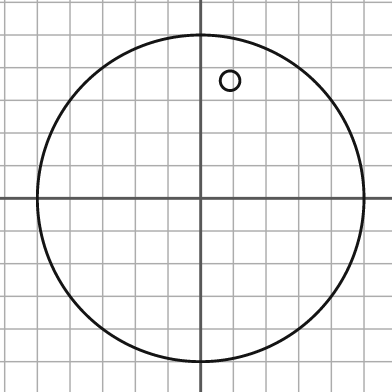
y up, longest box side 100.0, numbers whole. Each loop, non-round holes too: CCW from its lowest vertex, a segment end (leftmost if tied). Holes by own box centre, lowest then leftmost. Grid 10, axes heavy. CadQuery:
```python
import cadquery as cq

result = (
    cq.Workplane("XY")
    .moveTo(0.0, 0.0)
    .circle(50.0)
    .moveTo(9.0, 36.0)
    .circle(3.0)
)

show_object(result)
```